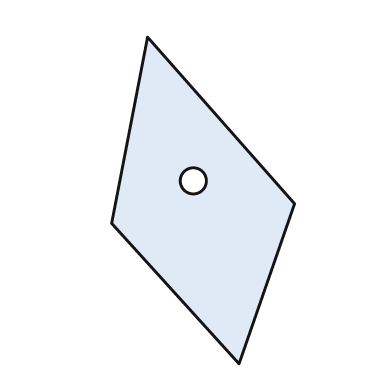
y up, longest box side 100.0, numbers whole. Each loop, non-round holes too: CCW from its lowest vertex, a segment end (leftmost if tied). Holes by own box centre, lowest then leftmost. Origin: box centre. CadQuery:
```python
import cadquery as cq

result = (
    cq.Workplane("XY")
    .moveTo(11.0, -50.0)
    .lineTo(28.0, -1.0)
    .lineTo(-17.0, 50.0)
    .lineTo(-28.0, -7.0)
    .close()
    .moveTo(-3.0, 6.0)
    .circle(4.0)
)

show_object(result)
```